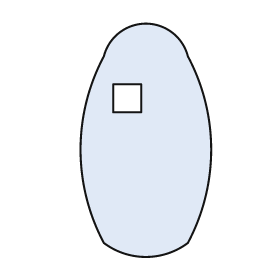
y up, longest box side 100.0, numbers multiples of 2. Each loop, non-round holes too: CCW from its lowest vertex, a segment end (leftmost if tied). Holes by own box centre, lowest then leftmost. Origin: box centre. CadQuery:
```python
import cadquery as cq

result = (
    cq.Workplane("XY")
    .moveTo(-18.0, -44.0)
    .threePointArc((0.0, -50.0), (18.0, -44.0))
    .threePointArc((28.0, -4.0), (18.0, 36.0))
    .threePointArc((0.0, 50.0), (-18.0, 36.0))
    .threePointArc((-28.0, -4.0), (-18.0, -44.0))
    .close()
    .moveTo(-14.0, 12.0)
    .lineTo(-2.0, 12.0)
    .lineTo(-2.0, 24.0)
    .lineTo(-14.0, 24.0)
    .close()
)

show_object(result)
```